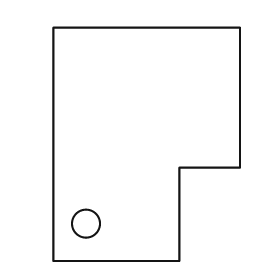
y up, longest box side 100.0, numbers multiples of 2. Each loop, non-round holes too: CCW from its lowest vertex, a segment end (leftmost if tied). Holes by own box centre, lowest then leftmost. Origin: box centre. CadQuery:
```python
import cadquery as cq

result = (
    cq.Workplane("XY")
    .moveTo(-40.0, -50.0)
    .lineTo(14.0, -50.0)
    .lineTo(14.0, -10.0)
    .lineTo(40.0, -10.0)
    .lineTo(40.0, 50.0)
    .lineTo(-40.0, 50.0)
    .close()
    .moveTo(-26.0, -34.0)
    .circle(6.0)
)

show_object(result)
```